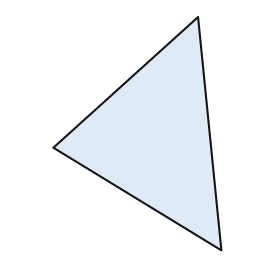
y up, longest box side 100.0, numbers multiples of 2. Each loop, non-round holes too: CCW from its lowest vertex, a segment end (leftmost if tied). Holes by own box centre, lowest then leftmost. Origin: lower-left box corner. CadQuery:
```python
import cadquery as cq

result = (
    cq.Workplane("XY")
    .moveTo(72.0, 0.0)
    .lineTo(62.0, 100.0)
    .lineTo(0.0, 44.0)
    .close()
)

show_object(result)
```